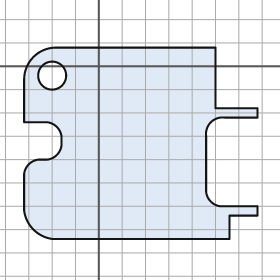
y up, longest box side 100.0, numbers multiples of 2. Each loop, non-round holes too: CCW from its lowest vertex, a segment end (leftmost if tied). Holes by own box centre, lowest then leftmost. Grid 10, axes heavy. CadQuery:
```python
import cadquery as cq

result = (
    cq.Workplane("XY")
    .moveTo(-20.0, -74.0)
    .lineTo(56.0, -74.0)
    .lineTo(56.0, -64.0)
    .lineTo(68.0, -64.0)
    .lineTo(68.0, -60.0)
    .lineTo(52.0, -60.0)
    .threePointArc((48.0, -58.0), (46.0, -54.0))
    .lineTo(46.0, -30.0)
    .threePointArc((48.0, -24.0), (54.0, -22.0))
    .lineTo(68.0, -22.0)
    .lineTo(68.0, -18.0)
    .lineTo(50.0, -18.0)
    .lineTo(50.0, 8.0)
    .lineTo(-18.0, 8.0)
    .threePointArc((-28.0, 4.0), (-32.0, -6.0))
    .lineTo(-32.0, -24.0)
    .lineTo(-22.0, -24.0)
    .threePointArc((-18.0, -26.0), (-16.0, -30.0))
    .lineTo(-16.0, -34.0)
    .threePointArc((-18.0, -38.0), (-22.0, -40.0))
    .lineTo(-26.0, -40.0)
    .threePointArc((-30.0, -42.0), (-32.0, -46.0))
    .lineTo(-32.0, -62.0)
    .threePointArc((-28.0, -70.0), (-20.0, -74.0))
    .close()
    .moveTo(-20.0, -4.0)
    .circle(6.0)
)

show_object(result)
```